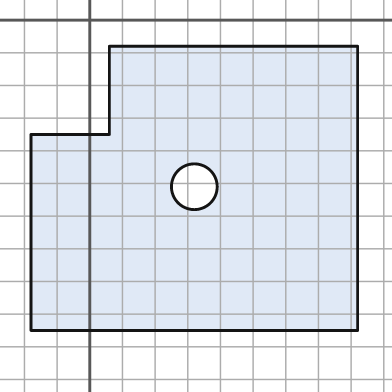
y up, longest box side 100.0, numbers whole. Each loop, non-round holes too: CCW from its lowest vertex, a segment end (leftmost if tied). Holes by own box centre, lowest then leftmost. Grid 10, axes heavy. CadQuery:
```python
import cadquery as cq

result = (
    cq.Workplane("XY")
    .moveTo(-18.0, -95.0)
    .lineTo(82.0, -95.0)
    .lineTo(82.0, -8.0)
    .lineTo(6.0, -8.0)
    .lineTo(6.0, -35.0)
    .lineTo(-18.0, -35.0)
    .close()
    .moveTo(32.0, -51.0)
    .circle(7.0)
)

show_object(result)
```